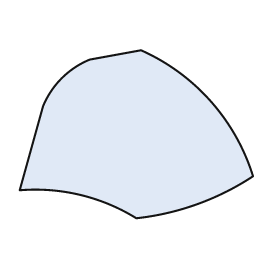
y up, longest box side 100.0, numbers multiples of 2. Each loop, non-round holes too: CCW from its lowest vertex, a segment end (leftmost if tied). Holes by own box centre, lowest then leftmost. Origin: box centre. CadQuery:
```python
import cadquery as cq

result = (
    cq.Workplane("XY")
    .moveTo(0.0, -36.0)
    .threePointArc((26.0, -30.0), (50.0, -18.0))
    .threePointArc((32.0, 14.0), (2.0, 36.0))
    .lineTo(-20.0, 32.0)
    .threePointArc((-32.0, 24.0), (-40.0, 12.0))
    .lineTo(-50.0, -24.0)
    .threePointArc((-24.0, -26.0), (0.0, -36.0))
    .close()
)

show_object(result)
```